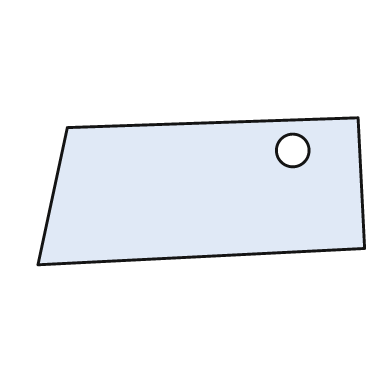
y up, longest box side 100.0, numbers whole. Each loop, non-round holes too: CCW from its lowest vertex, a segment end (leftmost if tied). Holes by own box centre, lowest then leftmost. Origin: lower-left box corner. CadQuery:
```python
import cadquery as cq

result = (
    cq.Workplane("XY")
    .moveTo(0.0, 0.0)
    .lineTo(100.0, 5.0)
    .lineTo(98.0, 45.0)
    .lineTo(9.0, 42.0)
    .close()
    .moveTo(78.0, 35.0)
    .circle(5.0)
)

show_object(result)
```